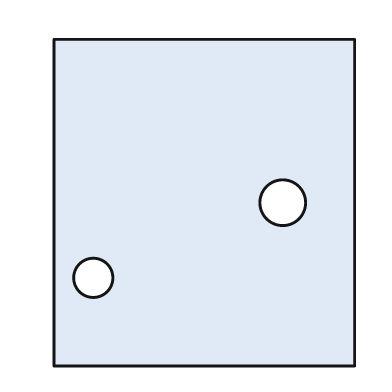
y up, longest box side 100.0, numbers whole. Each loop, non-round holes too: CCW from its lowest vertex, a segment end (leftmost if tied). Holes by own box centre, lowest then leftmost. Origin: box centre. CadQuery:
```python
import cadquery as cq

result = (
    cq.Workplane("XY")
    .moveTo(-46.0, -50.0)
    .lineTo(46.0, -50.0)
    .lineTo(46.0, 50.0)
    .lineTo(-46.0, 50.0)
    .close()
    .moveTo(-34.0, -23.0)
    .circle(6.0)
    .moveTo(24.0, 0.0)
    .circle(7.0)
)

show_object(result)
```